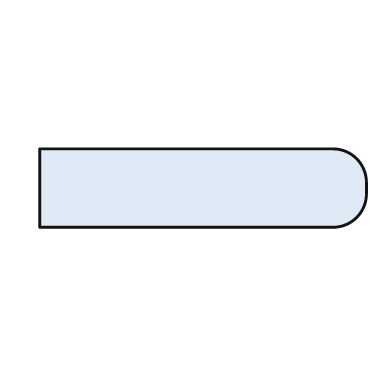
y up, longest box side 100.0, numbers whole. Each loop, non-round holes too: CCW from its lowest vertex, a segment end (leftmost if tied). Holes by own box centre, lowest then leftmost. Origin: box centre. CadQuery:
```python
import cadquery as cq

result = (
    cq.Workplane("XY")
    .moveTo(-50.0, -12.0)
    .lineTo(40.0, -12.0)
    .threePointArc((47.0, -9.0), (50.0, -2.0))
    .lineTo(50.0, 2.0)
    .threePointArc((47.0, 9.0), (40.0, 12.0))
    .lineTo(-50.0, 12.0)
    .close()
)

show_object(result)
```